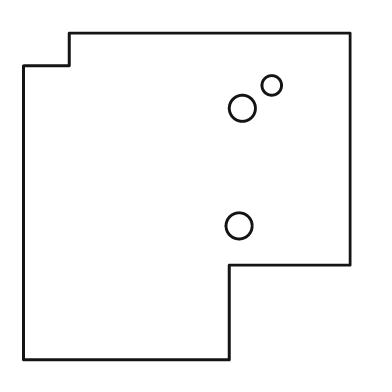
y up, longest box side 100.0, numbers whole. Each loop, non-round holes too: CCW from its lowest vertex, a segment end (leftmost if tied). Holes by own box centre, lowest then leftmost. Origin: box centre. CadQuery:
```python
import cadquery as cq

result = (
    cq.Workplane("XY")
    .moveTo(-50.0, -50.0)
    .lineTo(13.0, -50.0)
    .lineTo(13.0, -21.0)
    .lineTo(50.0, -21.0)
    .lineTo(50.0, 50.0)
    .lineTo(-36.0, 50.0)
    .lineTo(-36.0, 40.0)
    .lineTo(-50.0, 40.0)
    .close()
    .moveTo(16.0, -9.0)
    .circle(4.0)
    .moveTo(17.0, 27.0)
    .circle(4.0)
    .moveTo(26.0, 34.0)
    .circle(3.0)
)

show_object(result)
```